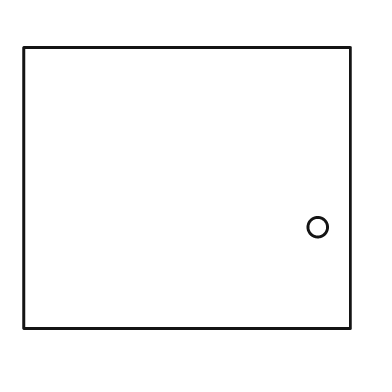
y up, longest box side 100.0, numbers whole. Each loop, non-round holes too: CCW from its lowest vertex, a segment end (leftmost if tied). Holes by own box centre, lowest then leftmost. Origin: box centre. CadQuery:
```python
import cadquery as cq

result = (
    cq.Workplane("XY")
    .moveTo(-50.0, -43.0)
    .lineTo(50.0, -43.0)
    .lineTo(50.0, 43.0)
    .lineTo(-50.0, 43.0)
    .close()
    .moveTo(40.0, -12.0)
    .circle(3.0)
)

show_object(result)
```